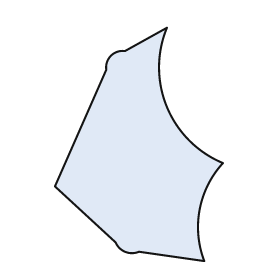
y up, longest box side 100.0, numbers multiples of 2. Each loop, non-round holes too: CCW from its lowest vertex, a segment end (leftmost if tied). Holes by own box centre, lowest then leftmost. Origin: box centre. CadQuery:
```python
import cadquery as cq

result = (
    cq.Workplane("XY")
    .moveTo(28.0, -50.0)
    .threePointArc((26.0, -28.0), (36.0, -8.0))
    .threePointArc((12.0, 16.0), (12.0, 50.0))
    .lineTo(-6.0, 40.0)
    .threePointArc((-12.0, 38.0), (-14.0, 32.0))
    .lineTo(-36.0, -18.0)
    .lineTo(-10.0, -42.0)
    .threePointArc((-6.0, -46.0), (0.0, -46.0))
    .close()
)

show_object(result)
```